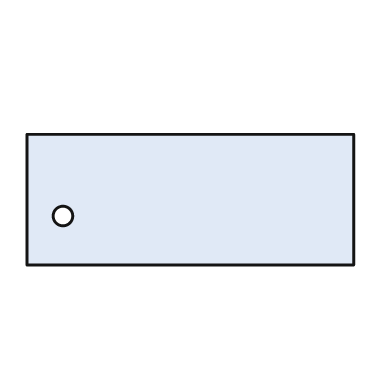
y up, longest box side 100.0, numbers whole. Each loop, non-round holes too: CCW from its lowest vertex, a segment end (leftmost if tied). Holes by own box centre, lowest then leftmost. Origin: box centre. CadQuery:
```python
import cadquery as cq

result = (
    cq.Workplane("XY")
    .moveTo(-50.0, -20.0)
    .lineTo(50.0, -20.0)
    .lineTo(50.0, 20.0)
    .lineTo(-50.0, 20.0)
    .close()
    .moveTo(-39.0, -5.0)
    .circle(3.0)
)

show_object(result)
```